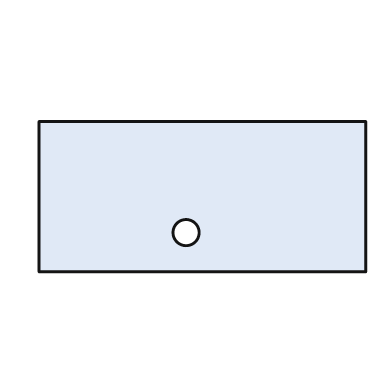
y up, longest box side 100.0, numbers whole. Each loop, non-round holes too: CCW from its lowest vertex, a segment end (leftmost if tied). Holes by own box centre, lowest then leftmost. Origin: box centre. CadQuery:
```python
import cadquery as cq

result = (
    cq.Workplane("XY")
    .moveTo(-50.0, -23.0)
    .lineTo(50.0, -23.0)
    .lineTo(50.0, 23.0)
    .lineTo(-50.0, 23.0)
    .close()
    .moveTo(-5.0, -11.0)
    .circle(4.0)
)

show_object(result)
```